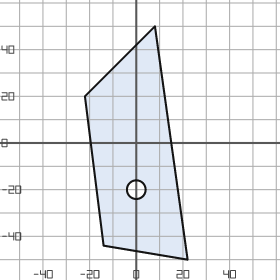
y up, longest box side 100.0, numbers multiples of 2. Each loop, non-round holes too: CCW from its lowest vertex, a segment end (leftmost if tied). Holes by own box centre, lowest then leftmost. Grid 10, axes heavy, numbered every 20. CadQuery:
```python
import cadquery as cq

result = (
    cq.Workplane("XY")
    .moveTo(22.0, -50.0)
    .lineTo(8.0, 50.0)
    .lineTo(-22.0, 20.0)
    .lineTo(-14.0, -44.0)
    .close()
    .moveTo(0.0, -20.0)
    .circle(4.0)
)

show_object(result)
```